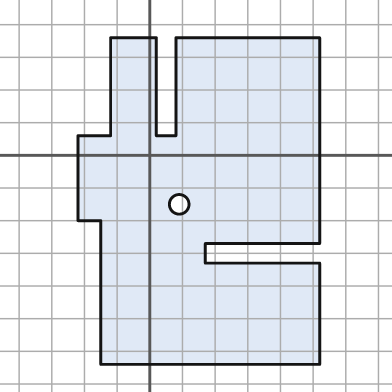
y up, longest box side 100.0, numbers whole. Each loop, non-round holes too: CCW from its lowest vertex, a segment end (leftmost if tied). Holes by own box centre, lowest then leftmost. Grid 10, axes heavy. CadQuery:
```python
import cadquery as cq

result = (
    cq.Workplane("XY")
    .moveTo(-15.0, -64.0)
    .lineTo(52.0, -64.0)
    .lineTo(52.0, -33.0)
    .lineTo(17.0, -33.0)
    .lineTo(17.0, -27.0)
    .lineTo(52.0, -27.0)
    .lineTo(52.0, 36.0)
    .lineTo(8.0, 36.0)
    .lineTo(8.0, 6.0)
    .lineTo(2.0, 6.0)
    .lineTo(2.0, 36.0)
    .lineTo(-12.0, 36.0)
    .lineTo(-12.0, 6.0)
    .lineTo(-22.0, 6.0)
    .lineTo(-22.0, -20.0)
    .lineTo(-15.0, -20.0)
    .close()
    .moveTo(9.0, -15.0)
    .circle(3.0)
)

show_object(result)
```